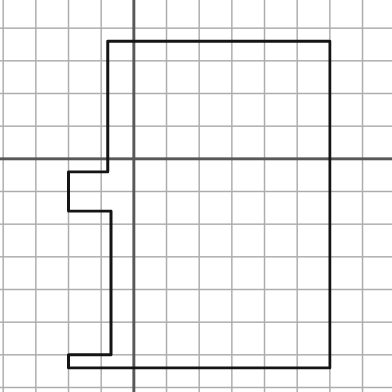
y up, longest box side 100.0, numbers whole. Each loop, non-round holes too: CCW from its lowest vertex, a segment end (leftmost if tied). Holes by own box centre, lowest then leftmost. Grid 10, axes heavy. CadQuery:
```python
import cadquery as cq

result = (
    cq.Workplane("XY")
    .moveTo(-20.0, -64.0)
    .lineTo(60.0, -64.0)
    .lineTo(60.0, 36.0)
    .lineTo(-8.0, 36.0)
    .lineTo(-8.0, -4.0)
    .lineTo(-20.0, -4.0)
    .lineTo(-20.0, -16.0)
    .lineTo(-7.0, -16.0)
    .lineTo(-7.0, -60.0)
    .lineTo(-20.0, -60.0)
    .close()
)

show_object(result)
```